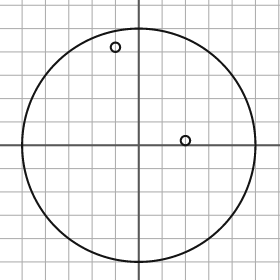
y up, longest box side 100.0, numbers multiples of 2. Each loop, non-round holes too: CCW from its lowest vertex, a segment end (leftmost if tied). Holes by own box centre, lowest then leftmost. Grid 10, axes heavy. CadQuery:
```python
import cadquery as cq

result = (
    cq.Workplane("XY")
    .moveTo(0.0, 0.0)
    .circle(50.0)
    .moveTo(20.0, 2.0)
    .circle(2.0)
    .moveTo(-10.0, 42.0)
    .circle(2.0)
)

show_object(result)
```